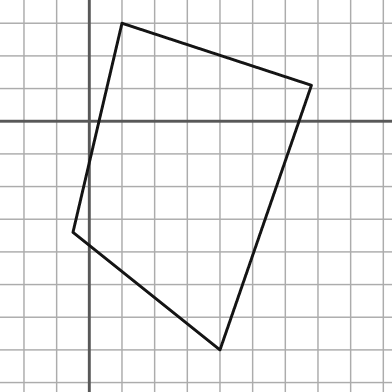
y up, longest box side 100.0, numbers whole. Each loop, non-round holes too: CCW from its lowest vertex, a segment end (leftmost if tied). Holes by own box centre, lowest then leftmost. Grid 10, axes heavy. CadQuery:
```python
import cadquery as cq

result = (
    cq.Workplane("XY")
    .moveTo(40.0, -70.0)
    .lineTo(68.0, 11.0)
    .lineTo(10.0, 30.0)
    .lineTo(-5.0, -34.0)
    .close()
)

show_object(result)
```